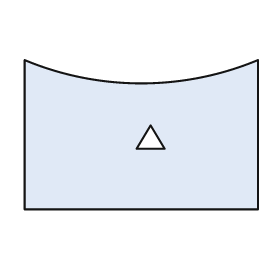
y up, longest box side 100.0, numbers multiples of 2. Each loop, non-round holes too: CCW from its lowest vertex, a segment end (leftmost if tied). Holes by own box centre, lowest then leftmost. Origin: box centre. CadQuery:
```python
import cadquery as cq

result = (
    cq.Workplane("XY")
    .moveTo(-50.0, -32.0)
    .lineTo(50.0, -32.0)
    .lineTo(50.0, 32.0)
    .threePointArc((0.0, 22.0), (-50.0, 32.0))
    .close()
    .moveTo(-2.0, -6.0)
    .lineTo(10.0, -6.0)
    .lineTo(4.0, 4.0)
    .close()
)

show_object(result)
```